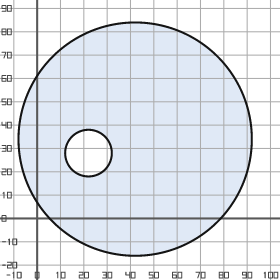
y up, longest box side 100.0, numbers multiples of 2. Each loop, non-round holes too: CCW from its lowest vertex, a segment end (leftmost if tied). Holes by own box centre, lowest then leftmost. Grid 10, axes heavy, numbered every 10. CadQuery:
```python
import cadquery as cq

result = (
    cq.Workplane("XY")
    .moveTo(42.0, 34.0)
    .circle(50.0)
    .moveTo(22.0, 28.0)
    .circle(10.0)
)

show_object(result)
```